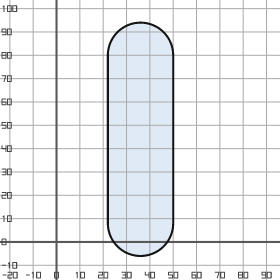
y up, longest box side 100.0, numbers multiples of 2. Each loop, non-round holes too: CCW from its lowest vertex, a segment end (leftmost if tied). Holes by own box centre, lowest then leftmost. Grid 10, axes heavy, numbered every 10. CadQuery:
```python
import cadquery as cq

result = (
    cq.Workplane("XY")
    .moveTo(22.0, 8.0)
    .threePointArc((36.0, -6.0), (50.0, 8.0))
    .lineTo(50.0, 80.0)
    .threePointArc((36.0, 94.0), (22.0, 80.0))
    .close()
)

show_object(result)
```